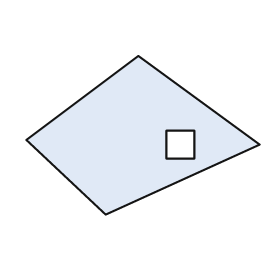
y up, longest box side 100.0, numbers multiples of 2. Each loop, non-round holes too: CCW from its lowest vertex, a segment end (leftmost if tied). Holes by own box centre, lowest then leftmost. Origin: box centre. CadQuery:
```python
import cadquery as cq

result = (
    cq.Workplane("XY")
    .moveTo(-16.0, -34.0)
    .lineTo(50.0, -4.0)
    .lineTo(-2.0, 34.0)
    .lineTo(-50.0, -2.0)
    .close()
    .moveTo(10.0, -10.0)
    .lineTo(22.0, -10.0)
    .lineTo(22.0, 2.0)
    .lineTo(10.0, 2.0)
    .close()
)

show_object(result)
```